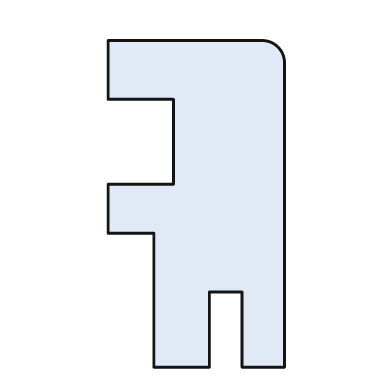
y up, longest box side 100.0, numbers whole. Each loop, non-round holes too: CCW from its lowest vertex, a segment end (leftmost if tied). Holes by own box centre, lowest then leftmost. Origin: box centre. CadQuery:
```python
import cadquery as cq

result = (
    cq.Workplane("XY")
    .moveTo(-13.0, -50.0)
    .lineTo(4.0, -50.0)
    .lineTo(4.0, -27.0)
    .lineTo(14.0, -27.0)
    .lineTo(14.0, -50.0)
    .lineTo(27.0, -50.0)
    .lineTo(27.0, 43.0)
    .threePointArc((25.0, 48.0), (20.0, 50.0))
    .lineTo(-27.0, 50.0)
    .lineTo(-27.0, 32.0)
    .lineTo(-7.0, 32.0)
    .lineTo(-7.0, 6.0)
    .lineTo(-27.0, 6.0)
    .lineTo(-27.0, -9.0)
    .lineTo(-13.0, -9.0)
    .close()
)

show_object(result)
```